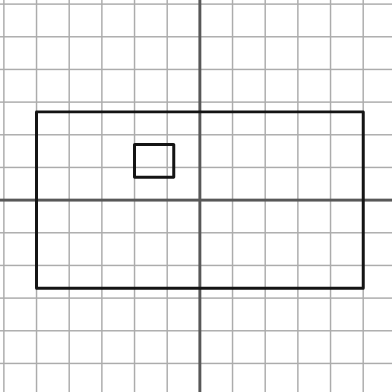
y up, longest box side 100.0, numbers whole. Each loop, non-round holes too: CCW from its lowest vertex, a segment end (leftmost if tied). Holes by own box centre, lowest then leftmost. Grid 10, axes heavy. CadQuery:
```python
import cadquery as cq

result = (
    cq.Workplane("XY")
    .moveTo(-50.0, -27.0)
    .lineTo(50.0, -27.0)
    .lineTo(50.0, 27.0)
    .lineTo(-50.0, 27.0)
    .close()
    .moveTo(-20.0, 7.0)
    .lineTo(-8.0, 7.0)
    .lineTo(-8.0, 17.0)
    .lineTo(-20.0, 17.0)
    .close()
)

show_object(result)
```